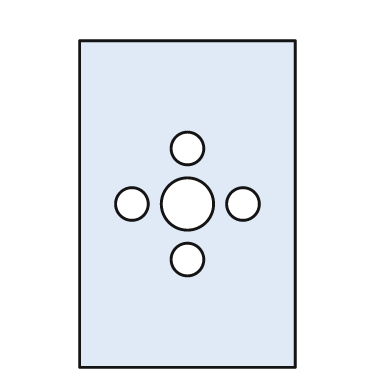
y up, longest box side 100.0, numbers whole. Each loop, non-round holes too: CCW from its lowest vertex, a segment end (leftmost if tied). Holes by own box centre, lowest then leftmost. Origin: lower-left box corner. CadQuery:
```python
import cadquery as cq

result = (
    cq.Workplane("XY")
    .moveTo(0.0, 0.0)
    .lineTo(66.0, 0.0)
    .lineTo(66.0, 100.0)
    .lineTo(0.0, 100.0)
    .close()
    .moveTo(33.0, 33.0)
    .circle(5.0)
    .moveTo(16.0, 50.0)
    .circle(5.0)
    .moveTo(33.0, 50.0)
    .circle(8.0)
    .moveTo(50.0, 50.0)
    .circle(5.0)
    .moveTo(33.0, 67.0)
    .circle(5.0)
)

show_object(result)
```